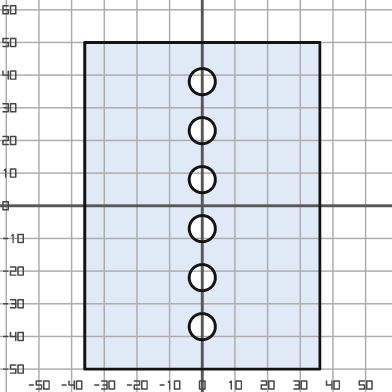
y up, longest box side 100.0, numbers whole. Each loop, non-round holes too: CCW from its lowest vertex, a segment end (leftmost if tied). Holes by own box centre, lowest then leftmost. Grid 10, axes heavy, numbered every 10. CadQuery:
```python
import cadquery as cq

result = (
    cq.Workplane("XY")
    .moveTo(-36.0, -50.0)
    .lineTo(36.0, -50.0)
    .lineTo(36.0, 50.0)
    .lineTo(-36.0, 50.0)
    .close()
    .moveTo(0.0, -37.0)
    .circle(4.0)
    .moveTo(0.0, -22.0)
    .circle(4.0)
    .moveTo(0.0, -7.0)
    .circle(4.0)
    .moveTo(0.0, 8.0)
    .circle(4.0)
    .moveTo(0.0, 23.0)
    .circle(4.0)
    .moveTo(0.0, 38.0)
    .circle(4.0)
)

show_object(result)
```